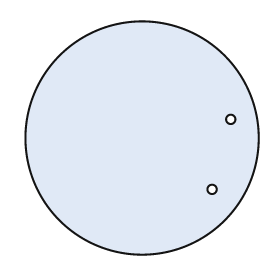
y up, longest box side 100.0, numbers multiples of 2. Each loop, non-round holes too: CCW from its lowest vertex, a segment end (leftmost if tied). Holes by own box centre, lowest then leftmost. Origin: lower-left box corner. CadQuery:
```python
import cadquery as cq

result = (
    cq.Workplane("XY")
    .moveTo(50.0, 50.0)
    .circle(50.0)
    .moveTo(80.0, 28.0)
    .circle(2.0)
    .moveTo(88.0, 58.0)
    .circle(2.0)
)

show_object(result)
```